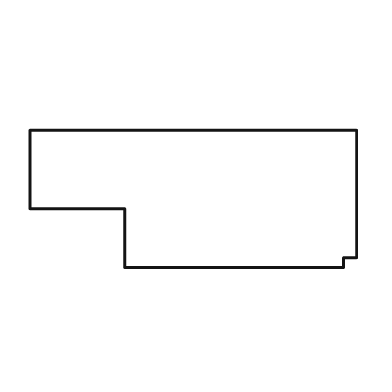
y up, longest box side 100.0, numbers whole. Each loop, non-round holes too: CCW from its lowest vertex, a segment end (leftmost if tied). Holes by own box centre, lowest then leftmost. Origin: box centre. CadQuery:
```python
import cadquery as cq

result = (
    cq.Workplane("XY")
    .moveTo(-21.0, -21.0)
    .lineTo(46.0, -21.0)
    .lineTo(46.0, -18.0)
    .lineTo(50.0, -18.0)
    .lineTo(50.0, 21.0)
    .lineTo(-50.0, 21.0)
    .lineTo(-50.0, -3.0)
    .lineTo(-21.0, -3.0)
    .close()
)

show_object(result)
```